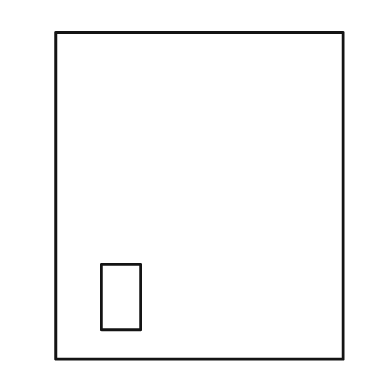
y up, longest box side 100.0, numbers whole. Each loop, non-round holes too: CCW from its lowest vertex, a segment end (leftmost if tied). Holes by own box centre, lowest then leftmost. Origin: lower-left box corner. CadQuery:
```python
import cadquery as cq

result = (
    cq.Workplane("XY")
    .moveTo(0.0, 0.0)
    .lineTo(88.0, 0.0)
    .lineTo(88.0, 100.0)
    .lineTo(0.0, 100.0)
    .close()
    .moveTo(14.0, 9.0)
    .lineTo(26.0, 9.0)
    .lineTo(26.0, 29.0)
    .lineTo(14.0, 29.0)
    .close()
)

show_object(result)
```